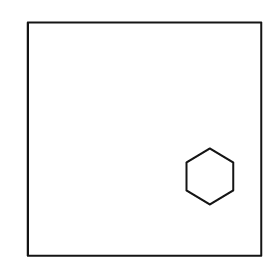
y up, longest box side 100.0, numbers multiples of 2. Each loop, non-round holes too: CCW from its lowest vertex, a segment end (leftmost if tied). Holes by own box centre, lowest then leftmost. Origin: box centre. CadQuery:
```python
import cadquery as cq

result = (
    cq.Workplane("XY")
    .moveTo(-50.0, -50.0)
    .lineTo(50.0, -50.0)
    .lineTo(50.0, 50.0)
    .lineTo(-50.0, 50.0)
    .close()
    .moveTo(28.0, -28.0)
    .lineTo(38.0, -22.0)
    .lineTo(38.0, -10.0)
    .lineTo(28.0, -4.0)
    .lineTo(18.0, -10.0)
    .lineTo(18.0, -22.0)
    .close()
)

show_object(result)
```